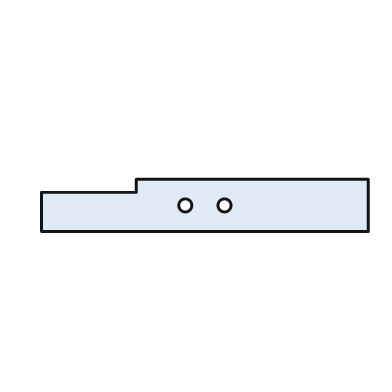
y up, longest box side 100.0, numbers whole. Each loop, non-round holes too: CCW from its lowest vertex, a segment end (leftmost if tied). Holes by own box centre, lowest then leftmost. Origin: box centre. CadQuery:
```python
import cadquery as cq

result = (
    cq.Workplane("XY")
    .moveTo(-50.0, -8.0)
    .lineTo(50.0, -8.0)
    .lineTo(50.0, 8.0)
    .lineTo(-21.0, 8.0)
    .lineTo(-21.0, 4.0)
    .lineTo(-50.0, 4.0)
    .close()
    .moveTo(-6.0, 0.0)
    .circle(2.0)
    .moveTo(6.0, 0.0)
    .circle(2.0)
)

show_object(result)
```